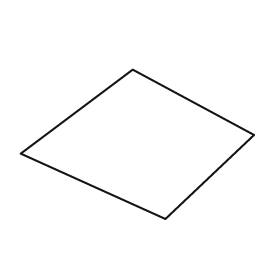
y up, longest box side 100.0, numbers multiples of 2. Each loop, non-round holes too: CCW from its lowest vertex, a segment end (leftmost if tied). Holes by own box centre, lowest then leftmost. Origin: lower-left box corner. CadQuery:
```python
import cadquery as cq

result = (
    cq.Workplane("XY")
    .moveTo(62.0, 0.0)
    .lineTo(100.0, 36.0)
    .lineTo(48.0, 64.0)
    .lineTo(0.0, 28.0)
    .close()
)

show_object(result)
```